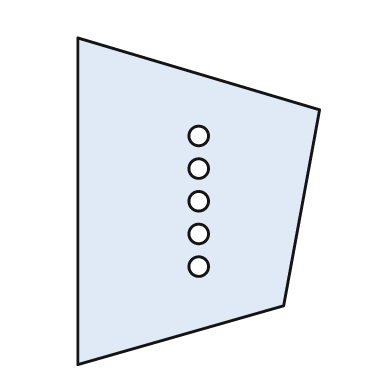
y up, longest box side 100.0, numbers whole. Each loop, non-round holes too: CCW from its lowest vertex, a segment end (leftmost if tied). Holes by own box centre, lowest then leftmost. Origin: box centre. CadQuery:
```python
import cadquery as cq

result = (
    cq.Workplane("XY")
    .moveTo(-37.0, -50.0)
    .lineTo(26.0, -32.0)
    .lineTo(37.0, 28.0)
    .lineTo(-37.0, 50.0)
    .close()
    .moveTo(0.0, -20.0)
    .circle(3.0)
    .moveTo(0.0, -10.0)
    .circle(3.0)
    .moveTo(0.0, 0.0)
    .circle(3.0)
    .moveTo(0.0, 10.0)
    .circle(3.0)
    .moveTo(0.0, 20.0)
    .circle(3.0)
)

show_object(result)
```